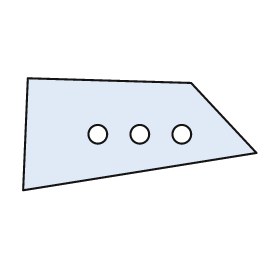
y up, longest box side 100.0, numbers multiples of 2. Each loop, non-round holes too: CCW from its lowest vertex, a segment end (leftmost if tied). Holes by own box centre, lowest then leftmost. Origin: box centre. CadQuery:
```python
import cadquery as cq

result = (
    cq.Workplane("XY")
    .moveTo(-50.0, -24.0)
    .lineTo(50.0, -8.0)
    .lineTo(22.0, 22.0)
    .lineTo(-48.0, 24.0)
    .close()
    .moveTo(-18.0, 0.0)
    .circle(4.0)
    .moveTo(0.0, 0.0)
    .circle(4.0)
    .moveTo(18.0, 0.0)
    .circle(4.0)
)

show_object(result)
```